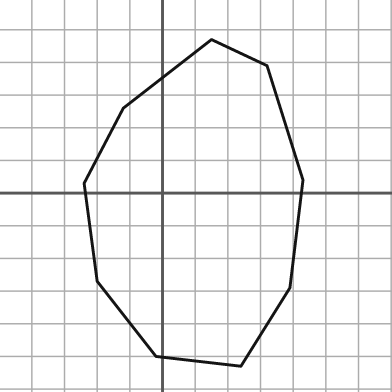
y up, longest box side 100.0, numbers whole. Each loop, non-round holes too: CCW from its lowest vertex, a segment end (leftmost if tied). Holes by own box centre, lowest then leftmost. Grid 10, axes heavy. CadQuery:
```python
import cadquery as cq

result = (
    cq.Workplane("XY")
    .moveTo(24.0, -53.0)
    .lineTo(39.0, -29.0)
    .lineTo(43.0, 4.0)
    .lineTo(32.0, 39.0)
    .lineTo(15.0, 47.0)
    .lineTo(-12.0, 26.0)
    .lineTo(-24.0, 3.0)
    .lineTo(-20.0, -27.0)
    .lineTo(-2.0, -50.0)
    .close()
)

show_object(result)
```